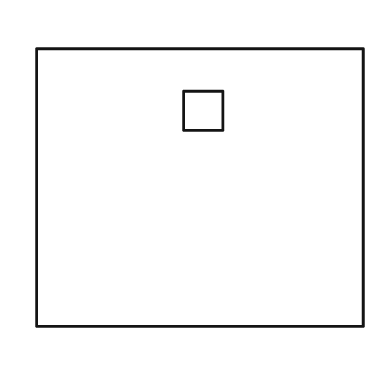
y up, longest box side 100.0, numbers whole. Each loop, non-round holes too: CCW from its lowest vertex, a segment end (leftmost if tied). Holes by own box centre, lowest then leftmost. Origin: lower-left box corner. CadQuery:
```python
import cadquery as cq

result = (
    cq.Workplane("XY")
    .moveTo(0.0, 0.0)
    .lineTo(100.0, 0.0)
    .lineTo(100.0, 85.0)
    .lineTo(0.0, 85.0)
    .close()
    .moveTo(45.0, 60.0)
    .lineTo(57.0, 60.0)
    .lineTo(57.0, 72.0)
    .lineTo(45.0, 72.0)
    .close()
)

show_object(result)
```